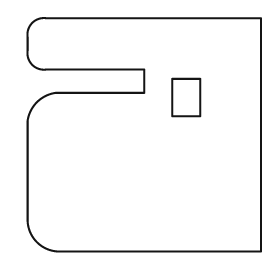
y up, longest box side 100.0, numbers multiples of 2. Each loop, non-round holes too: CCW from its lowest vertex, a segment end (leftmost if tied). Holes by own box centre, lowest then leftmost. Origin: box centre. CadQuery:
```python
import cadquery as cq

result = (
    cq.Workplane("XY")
    .moveTo(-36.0, -50.0)
    .lineTo(50.0, -50.0)
    .lineTo(50.0, 50.0)
    .lineTo(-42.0, 50.0)
    .threePointArc((-48.0, 48.0), (-50.0, 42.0))
    .lineTo(-50.0, 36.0)
    .threePointArc((-48.0, 30.0), (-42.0, 28.0))
    .lineTo(0.0, 28.0)
    .lineTo(0.0, 18.0)
    .lineTo(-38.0, 18.0)
    .threePointArc((-46.0, 14.0), (-50.0, 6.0))
    .lineTo(-50.0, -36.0)
    .threePointArc((-46.0, -46.0), (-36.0, -50.0))
    .close()
    .moveTo(12.0, 8.0)
    .lineTo(24.0, 8.0)
    .lineTo(24.0, 24.0)
    .lineTo(12.0, 24.0)
    .close()
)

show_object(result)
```